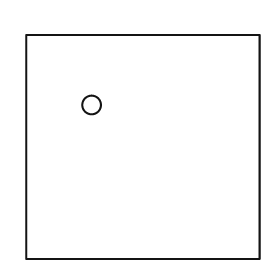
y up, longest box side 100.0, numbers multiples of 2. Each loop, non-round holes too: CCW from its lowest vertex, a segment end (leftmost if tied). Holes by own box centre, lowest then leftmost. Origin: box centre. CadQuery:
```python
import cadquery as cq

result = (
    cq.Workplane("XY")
    .moveTo(-50.0, -48.0)
    .lineTo(50.0, -48.0)
    .lineTo(50.0, 48.0)
    .lineTo(-50.0, 48.0)
    .close()
    .moveTo(-22.0, 18.0)
    .circle(4.0)
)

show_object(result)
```